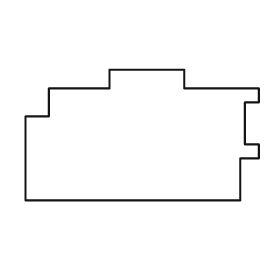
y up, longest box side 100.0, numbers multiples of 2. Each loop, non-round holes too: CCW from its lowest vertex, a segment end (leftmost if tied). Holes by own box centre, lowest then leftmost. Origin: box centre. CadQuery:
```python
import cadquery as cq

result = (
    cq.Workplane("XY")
    .moveTo(-50.0, -28.0)
    .lineTo(42.0, -28.0)
    .lineTo(42.0, -10.0)
    .lineTo(50.0, -10.0)
    .lineTo(50.0, -4.0)
    .lineTo(44.0, -4.0)
    .lineTo(44.0, 14.0)
    .lineTo(50.0, 14.0)
    .lineTo(50.0, 20.0)
    .lineTo(18.0, 20.0)
    .lineTo(18.0, 28.0)
    .lineTo(-14.0, 28.0)
    .lineTo(-14.0, 20.0)
    .lineTo(-40.0, 20.0)
    .lineTo(-40.0, 8.0)
    .lineTo(-50.0, 8.0)
    .close()
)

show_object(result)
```